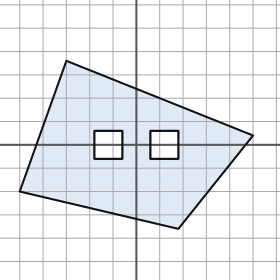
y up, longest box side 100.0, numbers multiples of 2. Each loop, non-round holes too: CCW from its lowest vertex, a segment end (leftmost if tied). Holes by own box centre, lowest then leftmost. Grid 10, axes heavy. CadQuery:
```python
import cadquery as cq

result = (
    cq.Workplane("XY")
    .moveTo(18.0, -36.0)
    .lineTo(50.0, 4.0)
    .lineTo(-30.0, 36.0)
    .lineTo(-50.0, -20.0)
    .close()
    .moveTo(-18.0, -6.0)
    .lineTo(-6.0, -6.0)
    .lineTo(-6.0, 6.0)
    .lineTo(-18.0, 6.0)
    .close()
    .moveTo(6.0, -6.0)
    .lineTo(18.0, -6.0)
    .lineTo(18.0, 6.0)
    .lineTo(6.0, 6.0)
    .close()
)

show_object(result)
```